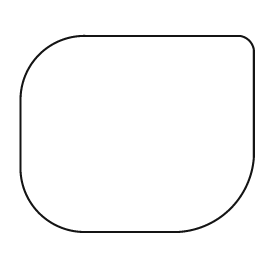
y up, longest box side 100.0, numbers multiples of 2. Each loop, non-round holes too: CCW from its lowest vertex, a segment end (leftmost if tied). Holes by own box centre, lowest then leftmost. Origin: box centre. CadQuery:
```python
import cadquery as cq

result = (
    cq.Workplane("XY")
    .moveTo(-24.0, -42.0)
    .lineTo(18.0, -42.0)
    .threePointArc((40.0, -32.0), (50.0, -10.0))
    .lineTo(50.0, 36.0)
    .threePointArc((48.0, 40.0), (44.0, 42.0))
    .lineTo(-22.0, 42.0)
    .threePointArc((-42.0, 34.0), (-50.0, 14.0))
    .lineTo(-50.0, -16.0)
    .threePointArc((-42.0, -34.0), (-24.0, -42.0))
    .close()
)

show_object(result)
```